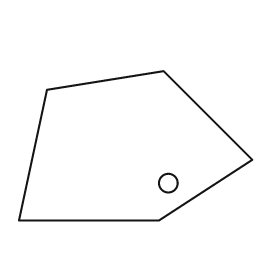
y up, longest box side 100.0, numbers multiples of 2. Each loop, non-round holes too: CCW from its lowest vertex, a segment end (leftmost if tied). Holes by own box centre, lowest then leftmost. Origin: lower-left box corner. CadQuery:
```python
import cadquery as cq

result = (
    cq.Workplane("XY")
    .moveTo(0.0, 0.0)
    .lineTo(60.0, 0.0)
    .lineTo(100.0, 26.0)
    .lineTo(62.0, 64.0)
    .lineTo(12.0, 56.0)
    .close()
    .moveTo(64.0, 16.0)
    .circle(4.0)
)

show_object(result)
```